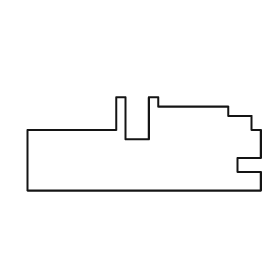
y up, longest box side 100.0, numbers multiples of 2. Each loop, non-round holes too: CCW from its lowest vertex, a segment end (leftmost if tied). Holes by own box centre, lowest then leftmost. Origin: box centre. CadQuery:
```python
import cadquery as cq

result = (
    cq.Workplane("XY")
    .moveTo(-50.0, -20.0)
    .lineTo(50.0, -20.0)
    .lineTo(50.0, -12.0)
    .lineTo(40.0, -12.0)
    .lineTo(40.0, -6.0)
    .lineTo(50.0, -6.0)
    .lineTo(50.0, 6.0)
    .lineTo(46.0, 6.0)
    .lineTo(46.0, 12.0)
    .lineTo(36.0, 12.0)
    .lineTo(36.0, 16.0)
    .lineTo(6.0, 16.0)
    .lineTo(6.0, 20.0)
    .lineTo(2.0, 20.0)
    .lineTo(2.0, 2.0)
    .lineTo(-8.0, 2.0)
    .lineTo(-8.0, 20.0)
    .lineTo(-12.0, 20.0)
    .lineTo(-12.0, 6.0)
    .lineTo(-50.0, 6.0)
    .close()
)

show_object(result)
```